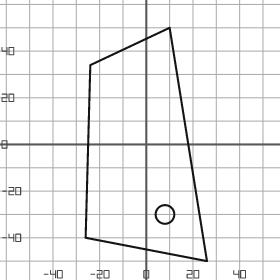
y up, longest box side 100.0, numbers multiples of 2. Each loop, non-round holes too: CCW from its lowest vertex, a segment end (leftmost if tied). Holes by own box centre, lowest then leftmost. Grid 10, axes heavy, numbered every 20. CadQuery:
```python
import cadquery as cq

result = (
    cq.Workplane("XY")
    .moveTo(26.0, -50.0)
    .lineTo(10.0, 50.0)
    .lineTo(-24.0, 34.0)
    .lineTo(-26.0, -40.0)
    .close()
    .moveTo(8.0, -30.0)
    .circle(4.0)
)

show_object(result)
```